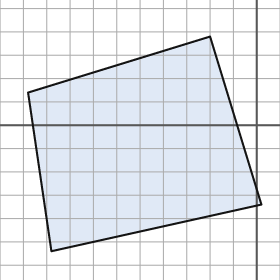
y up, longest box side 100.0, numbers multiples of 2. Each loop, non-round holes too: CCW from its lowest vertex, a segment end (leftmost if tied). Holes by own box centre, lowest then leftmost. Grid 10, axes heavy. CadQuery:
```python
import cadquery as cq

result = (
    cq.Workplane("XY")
    .moveTo(-88.0, -54.0)
    .lineTo(2.0, -34.0)
    .lineTo(-20.0, 38.0)
    .lineTo(-98.0, 14.0)
    .close()
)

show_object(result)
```